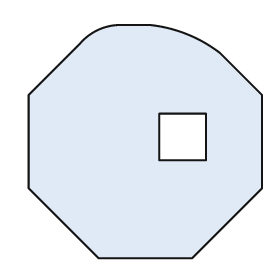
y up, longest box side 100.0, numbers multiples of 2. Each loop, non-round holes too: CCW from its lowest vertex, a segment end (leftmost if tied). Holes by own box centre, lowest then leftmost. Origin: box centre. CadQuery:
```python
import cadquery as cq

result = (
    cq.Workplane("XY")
    .moveTo(-20.0, -50.0)
    .lineTo(20.0, -50.0)
    .lineTo(50.0, -20.0)
    .lineTo(50.0, 20.0)
    .lineTo(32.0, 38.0)
    .threePointArc((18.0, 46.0), (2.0, 50.0))
    .lineTo(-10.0, 50.0)
    .threePointArc((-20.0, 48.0), (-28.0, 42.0))
    .lineTo(-50.0, 20.0)
    .lineTo(-50.0, -20.0)
    .close()
    .moveTo(6.0, -8.0)
    .lineTo(26.0, -8.0)
    .lineTo(26.0, 12.0)
    .lineTo(6.0, 12.0)
    .close()
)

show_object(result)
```